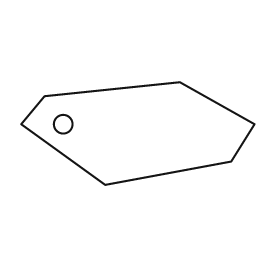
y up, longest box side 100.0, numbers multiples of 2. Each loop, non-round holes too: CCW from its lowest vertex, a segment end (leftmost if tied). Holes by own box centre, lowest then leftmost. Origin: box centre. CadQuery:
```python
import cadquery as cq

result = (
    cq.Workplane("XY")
    .moveTo(-14.0, -22.0)
    .lineTo(40.0, -12.0)
    .lineTo(50.0, 4.0)
    .lineTo(18.0, 22.0)
    .lineTo(-40.0, 16.0)
    .lineTo(-50.0, 4.0)
    .close()
    .moveTo(-32.0, 4.0)
    .circle(4.0)
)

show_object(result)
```